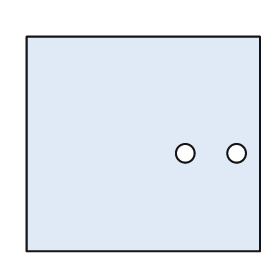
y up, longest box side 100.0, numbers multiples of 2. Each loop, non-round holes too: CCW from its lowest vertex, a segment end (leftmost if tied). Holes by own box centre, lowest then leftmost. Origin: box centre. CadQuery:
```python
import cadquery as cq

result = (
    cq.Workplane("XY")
    .moveTo(-50.0, -46.0)
    .lineTo(50.0, -46.0)
    .lineTo(50.0, 46.0)
    .lineTo(-50.0, 46.0)
    .close()
    .moveTo(18.0, -4.0)
    .circle(4.0)
    .moveTo(40.0, -4.0)
    .circle(4.0)
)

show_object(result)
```